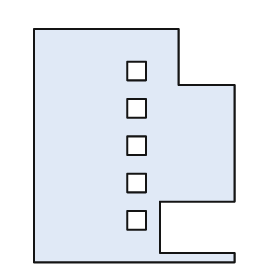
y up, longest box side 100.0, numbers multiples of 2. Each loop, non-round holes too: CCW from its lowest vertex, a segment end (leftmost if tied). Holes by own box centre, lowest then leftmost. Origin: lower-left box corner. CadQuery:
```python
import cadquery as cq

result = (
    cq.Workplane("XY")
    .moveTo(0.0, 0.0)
    .lineTo(86.0, 0.0)
    .lineTo(86.0, 4.0)
    .lineTo(54.0, 4.0)
    .lineTo(54.0, 26.0)
    .lineTo(86.0, 26.0)
    .lineTo(86.0, 76.0)
    .lineTo(62.0, 76.0)
    .lineTo(62.0, 100.0)
    .lineTo(0.0, 100.0)
    .close()
    .moveTo(40.0, 14.0)
    .lineTo(48.0, 14.0)
    .lineTo(48.0, 22.0)
    .lineTo(40.0, 22.0)
    .close()
    .moveTo(40.0, 30.0)
    .lineTo(48.0, 30.0)
    .lineTo(48.0, 38.0)
    .lineTo(40.0, 38.0)
    .close()
    .moveTo(40.0, 46.0)
    .lineTo(48.0, 46.0)
    .lineTo(48.0, 54.0)
    .lineTo(40.0, 54.0)
    .close()
    .moveTo(40.0, 62.0)
    .lineTo(48.0, 62.0)
    .lineTo(48.0, 70.0)
    .lineTo(40.0, 70.0)
    .close()
    .moveTo(40.0, 78.0)
    .lineTo(48.0, 78.0)
    .lineTo(48.0, 86.0)
    .lineTo(40.0, 86.0)
    .close()
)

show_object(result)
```